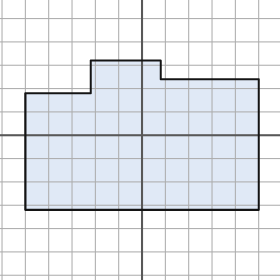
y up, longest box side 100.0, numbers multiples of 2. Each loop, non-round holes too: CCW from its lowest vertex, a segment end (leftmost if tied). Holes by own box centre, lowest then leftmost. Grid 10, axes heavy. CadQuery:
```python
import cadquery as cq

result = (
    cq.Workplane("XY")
    .moveTo(-50.0, -32.0)
    .lineTo(50.0, -32.0)
    .lineTo(50.0, 24.0)
    .lineTo(8.0, 24.0)
    .lineTo(8.0, 32.0)
    .lineTo(-22.0, 32.0)
    .lineTo(-22.0, 18.0)
    .lineTo(-50.0, 18.0)
    .close()
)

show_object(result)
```